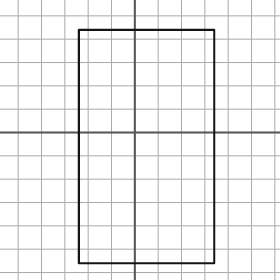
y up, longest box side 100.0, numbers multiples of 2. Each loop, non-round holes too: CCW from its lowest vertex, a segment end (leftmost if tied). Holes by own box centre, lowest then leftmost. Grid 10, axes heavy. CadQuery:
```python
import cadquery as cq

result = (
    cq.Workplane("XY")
    .moveTo(-24.0, -56.0)
    .lineTo(34.0, -56.0)
    .lineTo(34.0, 44.0)
    .lineTo(-24.0, 44.0)
    .close()
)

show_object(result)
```